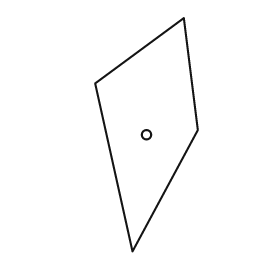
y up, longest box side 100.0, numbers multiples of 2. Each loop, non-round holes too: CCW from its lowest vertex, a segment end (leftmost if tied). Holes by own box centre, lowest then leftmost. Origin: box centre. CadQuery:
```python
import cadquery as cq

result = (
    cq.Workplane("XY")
    .moveTo(-6.0, -50.0)
    .lineTo(22.0, 2.0)
    .lineTo(16.0, 50.0)
    .lineTo(-22.0, 22.0)
    .close()
    .moveTo(0.0, 0.0)
    .circle(2.0)
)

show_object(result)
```